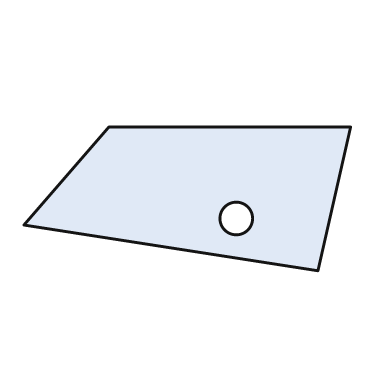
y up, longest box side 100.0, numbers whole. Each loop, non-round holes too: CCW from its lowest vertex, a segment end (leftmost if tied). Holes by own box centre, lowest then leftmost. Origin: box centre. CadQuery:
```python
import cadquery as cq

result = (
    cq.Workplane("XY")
    .moveTo(40.0, -22.0)
    .lineTo(50.0, 22.0)
    .lineTo(-24.0, 22.0)
    .lineTo(-50.0, -8.0)
    .close()
    .moveTo(15.0, -6.0)
    .circle(5.0)
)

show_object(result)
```